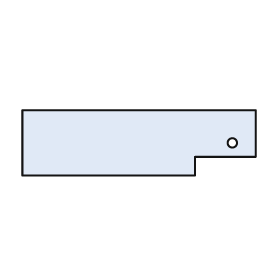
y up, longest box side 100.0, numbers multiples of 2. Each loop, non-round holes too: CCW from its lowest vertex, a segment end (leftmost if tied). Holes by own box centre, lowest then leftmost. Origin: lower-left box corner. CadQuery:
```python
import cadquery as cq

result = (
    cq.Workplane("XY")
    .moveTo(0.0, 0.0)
    .lineTo(74.0, 0.0)
    .lineTo(74.0, 8.0)
    .lineTo(100.0, 8.0)
    .lineTo(100.0, 28.0)
    .lineTo(0.0, 28.0)
    .close()
    .moveTo(90.0, 14.0)
    .circle(2.0)
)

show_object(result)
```